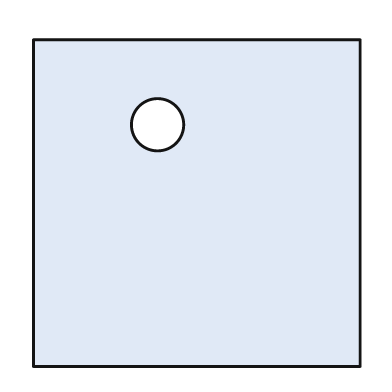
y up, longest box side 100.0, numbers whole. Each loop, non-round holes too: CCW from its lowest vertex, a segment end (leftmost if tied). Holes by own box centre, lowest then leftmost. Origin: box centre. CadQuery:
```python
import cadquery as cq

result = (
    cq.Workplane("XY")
    .moveTo(-50.0, -50.0)
    .lineTo(50.0, -50.0)
    .lineTo(50.0, 50.0)
    .lineTo(-50.0, 50.0)
    .close()
    .moveTo(-12.0, 24.0)
    .circle(8.0)
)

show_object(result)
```